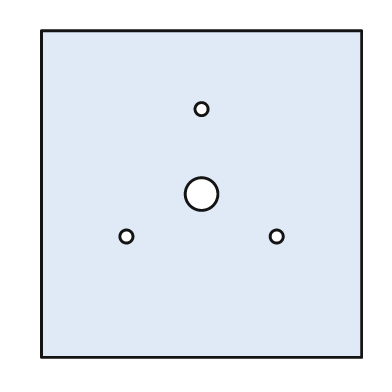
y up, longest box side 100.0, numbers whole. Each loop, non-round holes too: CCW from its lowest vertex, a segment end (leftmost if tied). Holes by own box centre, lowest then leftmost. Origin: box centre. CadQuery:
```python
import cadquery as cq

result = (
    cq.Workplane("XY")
    .moveTo(-49.0, -50.0)
    .lineTo(49.0, -50.0)
    .lineTo(49.0, 50.0)
    .lineTo(-49.0, 50.0)
    .close()
    .moveTo(-23.0, -13.0)
    .circle(2.0)
    .moveTo(23.0, -13.0)
    .circle(2.0)
    .moveTo(0.0, 0.0)
    .circle(5.0)
    .moveTo(0.0, 26.0)
    .circle(2.0)
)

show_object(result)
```